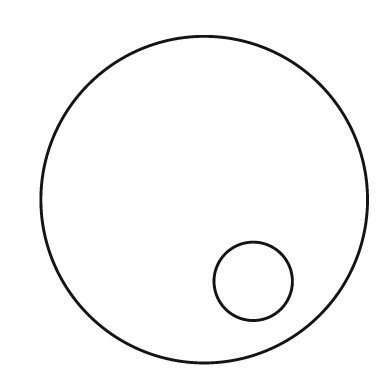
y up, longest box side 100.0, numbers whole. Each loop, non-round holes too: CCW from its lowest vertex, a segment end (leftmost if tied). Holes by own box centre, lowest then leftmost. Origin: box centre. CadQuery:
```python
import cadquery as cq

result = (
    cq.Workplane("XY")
    .moveTo(0.0, 0.0)
    .circle(50.0)
    .moveTo(15.0, -25.0)
    .circle(12.0)
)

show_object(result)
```